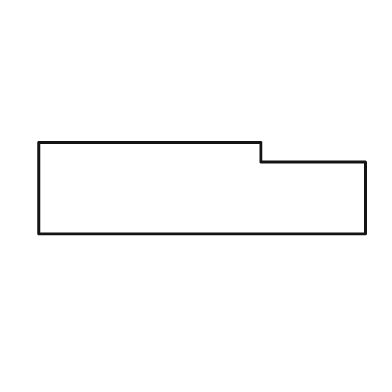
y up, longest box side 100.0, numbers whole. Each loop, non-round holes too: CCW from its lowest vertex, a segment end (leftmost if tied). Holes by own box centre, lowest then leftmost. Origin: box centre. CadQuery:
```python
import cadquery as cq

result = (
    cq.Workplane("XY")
    .moveTo(-50.0, -14.0)
    .lineTo(50.0, -14.0)
    .lineTo(50.0, 8.0)
    .lineTo(18.0, 8.0)
    .lineTo(18.0, 14.0)
    .lineTo(-50.0, 14.0)
    .close()
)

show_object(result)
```